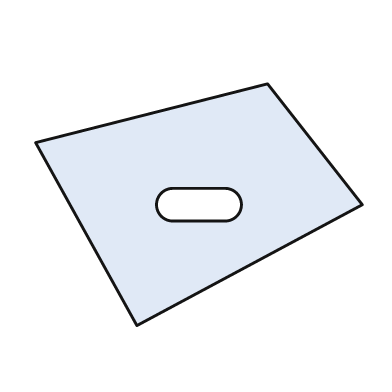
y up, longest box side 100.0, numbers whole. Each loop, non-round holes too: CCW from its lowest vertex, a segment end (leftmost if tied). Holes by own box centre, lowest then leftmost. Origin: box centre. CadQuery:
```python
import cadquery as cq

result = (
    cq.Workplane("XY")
    .moveTo(-19.0, -37.0)
    .lineTo(50.0, 0.0)
    .lineTo(21.0, 37.0)
    .lineTo(-50.0, 19.0)
    .close()
    .moveTo(-8.0, -5.0)
    .lineTo(8.0, -5.0)
    .threePointArc((13.0, 0.0), (8.0, 5.0))
    .lineTo(-8.0, 5.0)
    .threePointArc((-13.0, 0.0), (-8.0, -5.0))
    .close()
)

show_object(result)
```